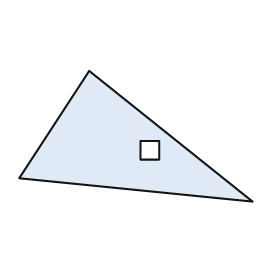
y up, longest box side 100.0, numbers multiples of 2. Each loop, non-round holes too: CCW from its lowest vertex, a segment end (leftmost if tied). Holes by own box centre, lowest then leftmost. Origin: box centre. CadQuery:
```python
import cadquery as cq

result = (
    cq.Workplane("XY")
    .moveTo(50.0, -28.0)
    .lineTo(-20.0, 28.0)
    .lineTo(-50.0, -18.0)
    .close()
    .moveTo(2.0, -10.0)
    .lineTo(10.0, -10.0)
    .lineTo(10.0, -2.0)
    .lineTo(2.0, -2.0)
    .close()
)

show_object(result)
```